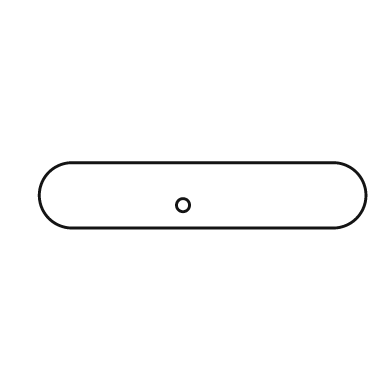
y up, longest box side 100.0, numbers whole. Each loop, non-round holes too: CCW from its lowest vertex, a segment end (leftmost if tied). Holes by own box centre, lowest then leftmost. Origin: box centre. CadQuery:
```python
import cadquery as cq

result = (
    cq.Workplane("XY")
    .moveTo(-40.0, -10.0)
    .lineTo(40.0, -10.0)
    .threePointArc((50.0, 0.0), (40.0, 10.0))
    .lineTo(-40.0, 10.0)
    .threePointArc((-50.0, 0.0), (-40.0, -10.0))
    .close()
    .moveTo(-6.0, -3.0)
    .circle(2.0)
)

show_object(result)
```